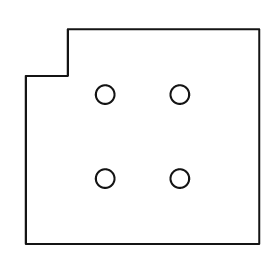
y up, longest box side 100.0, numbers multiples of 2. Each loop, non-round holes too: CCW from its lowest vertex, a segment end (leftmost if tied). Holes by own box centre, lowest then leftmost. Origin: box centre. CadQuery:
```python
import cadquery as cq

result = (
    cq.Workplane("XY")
    .moveTo(-50.0, -46.0)
    .lineTo(50.0, -46.0)
    .lineTo(50.0, 46.0)
    .lineTo(-32.0, 46.0)
    .lineTo(-32.0, 26.0)
    .lineTo(-50.0, 26.0)
    .close()
    .moveTo(-16.0, -18.0)
    .circle(4.0)
    .moveTo(16.0, -18.0)
    .circle(4.0)
    .moveTo(-16.0, 18.0)
    .circle(4.0)
    .moveTo(16.0, 18.0)
    .circle(4.0)
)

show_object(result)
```